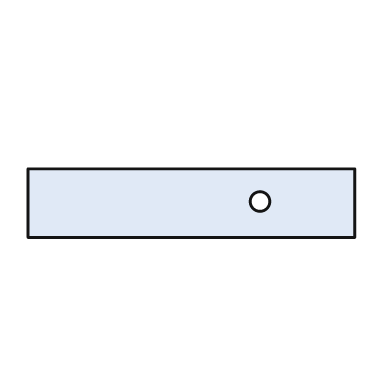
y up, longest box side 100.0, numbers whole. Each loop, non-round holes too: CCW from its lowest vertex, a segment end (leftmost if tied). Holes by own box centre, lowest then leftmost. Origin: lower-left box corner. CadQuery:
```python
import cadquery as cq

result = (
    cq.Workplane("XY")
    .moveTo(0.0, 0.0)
    .lineTo(100.0, 0.0)
    .lineTo(100.0, 21.0)
    .lineTo(0.0, 21.0)
    .close()
    .moveTo(71.0, 11.0)
    .circle(3.0)
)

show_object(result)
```